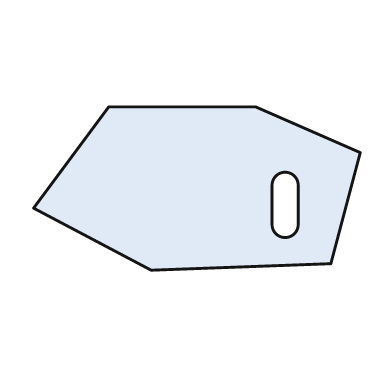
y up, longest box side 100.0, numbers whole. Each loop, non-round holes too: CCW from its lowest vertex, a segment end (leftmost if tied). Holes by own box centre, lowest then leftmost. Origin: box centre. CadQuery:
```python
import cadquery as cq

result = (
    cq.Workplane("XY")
    .moveTo(-14.0, -25.0)
    .lineTo(41.0, -23.0)
    .lineTo(50.0, 11.0)
    .lineTo(18.0, 25.0)
    .lineTo(-27.0, 25.0)
    .lineTo(-50.0, -6.0)
    .close()
    .moveTo(23.0, -11.0)
    .threePointArc((27.0, -15.0), (31.0, -11.0))
    .lineTo(31.0, 1.0)
    .threePointArc((27.0, 5.0), (23.0, 1.0))
    .close()
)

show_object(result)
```